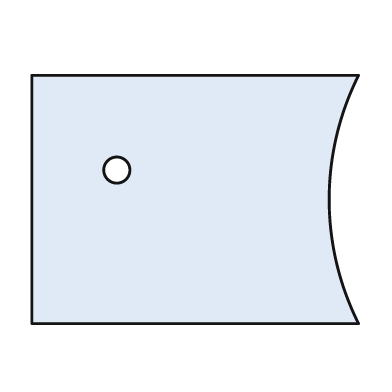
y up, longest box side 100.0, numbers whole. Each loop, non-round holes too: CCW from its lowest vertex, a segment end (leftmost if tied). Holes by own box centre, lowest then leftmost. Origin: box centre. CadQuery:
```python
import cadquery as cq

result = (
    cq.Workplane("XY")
    .moveTo(-50.0, -38.0)
    .lineTo(50.0, -38.0)
    .threePointArc((41.0, 0.0), (50.0, 38.0))
    .lineTo(-50.0, 38.0)
    .close()
    .moveTo(-24.0, 9.0)
    .circle(4.0)
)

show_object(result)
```